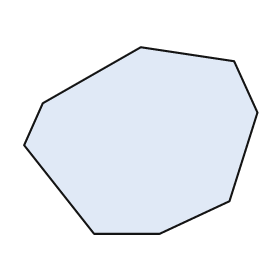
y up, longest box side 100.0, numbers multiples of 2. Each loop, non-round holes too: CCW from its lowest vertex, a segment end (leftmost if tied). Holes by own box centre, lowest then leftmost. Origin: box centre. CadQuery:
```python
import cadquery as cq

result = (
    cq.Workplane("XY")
    .moveTo(-20.0, -40.0)
    .lineTo(8.0, -40.0)
    .lineTo(38.0, -26.0)
    .lineTo(50.0, 12.0)
    .lineTo(40.0, 34.0)
    .lineTo(0.0, 40.0)
    .lineTo(-42.0, 16.0)
    .lineTo(-50.0, -2.0)
    .close()
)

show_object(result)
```